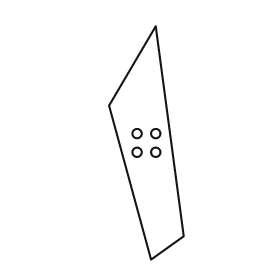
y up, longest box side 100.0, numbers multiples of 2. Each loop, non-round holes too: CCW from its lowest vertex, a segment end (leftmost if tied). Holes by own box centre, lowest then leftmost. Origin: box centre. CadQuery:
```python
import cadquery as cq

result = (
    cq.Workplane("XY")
    .moveTo(2.0, -50.0)
    .lineTo(16.0, -40.0)
    .lineTo(4.0, 50.0)
    .lineTo(-16.0, 16.0)
    .close()
    .moveTo(-4.0, -4.0)
    .circle(2.0)
    .moveTo(4.0, -4.0)
    .circle(2.0)
    .moveTo(-4.0, 4.0)
    .circle(2.0)
    .moveTo(4.0, 4.0)
    .circle(2.0)
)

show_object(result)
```